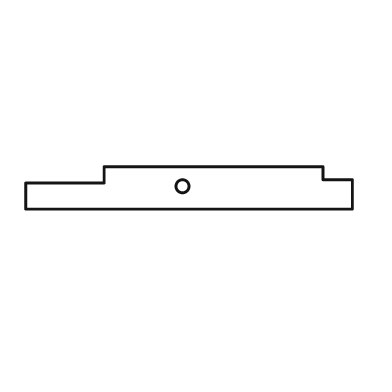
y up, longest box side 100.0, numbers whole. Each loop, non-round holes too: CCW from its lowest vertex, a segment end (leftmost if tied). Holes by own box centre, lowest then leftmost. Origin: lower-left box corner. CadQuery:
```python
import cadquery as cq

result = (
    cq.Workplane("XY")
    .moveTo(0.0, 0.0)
    .lineTo(100.0, 0.0)
    .lineTo(100.0, 9.0)
    .lineTo(91.0, 9.0)
    .lineTo(91.0, 13.0)
    .lineTo(24.0, 13.0)
    .lineTo(24.0, 8.0)
    .lineTo(0.0, 8.0)
    .close()
    .moveTo(48.0, 7.0)
    .circle(2.0)
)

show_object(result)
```